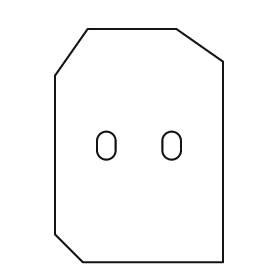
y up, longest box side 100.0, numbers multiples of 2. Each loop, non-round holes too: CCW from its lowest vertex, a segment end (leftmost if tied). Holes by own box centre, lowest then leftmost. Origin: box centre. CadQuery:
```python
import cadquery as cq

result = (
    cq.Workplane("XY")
    .moveTo(-24.0, -50.0)
    .lineTo(36.0, -50.0)
    .lineTo(36.0, 36.0)
    .lineTo(16.0, 50.0)
    .lineTo(-22.0, 50.0)
    .lineTo(-36.0, 30.0)
    .lineTo(-36.0, -38.0)
    .close()
    .moveTo(-18.0, -2.0)
    .threePointArc((-14.0, -6.0), (-10.0, -2.0))
    .lineTo(-10.0, 2.0)
    .threePointArc((-14.0, 6.0), (-18.0, 2.0))
    .close()
    .moveTo(10.0, -2.0)
    .threePointArc((14.0, -6.0), (18.0, -2.0))
    .lineTo(18.0, 2.0)
    .threePointArc((14.0, 6.0), (10.0, 2.0))
    .close()
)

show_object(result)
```